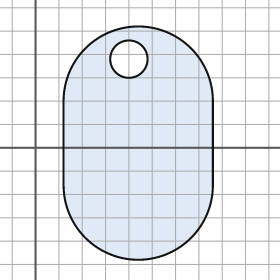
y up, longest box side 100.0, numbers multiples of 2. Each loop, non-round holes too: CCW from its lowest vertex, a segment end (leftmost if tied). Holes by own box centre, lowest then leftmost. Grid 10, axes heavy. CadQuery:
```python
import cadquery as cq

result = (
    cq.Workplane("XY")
    .moveTo(12.0, -16.0)
    .threePointArc((44.0, -48.0), (76.0, -16.0))
    .lineTo(76.0, 20.0)
    .threePointArc((44.0, 52.0), (12.0, 20.0))
    .close()
    .moveTo(40.0, 38.0)
    .circle(8.0)
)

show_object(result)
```